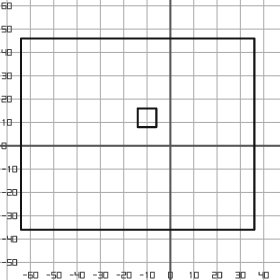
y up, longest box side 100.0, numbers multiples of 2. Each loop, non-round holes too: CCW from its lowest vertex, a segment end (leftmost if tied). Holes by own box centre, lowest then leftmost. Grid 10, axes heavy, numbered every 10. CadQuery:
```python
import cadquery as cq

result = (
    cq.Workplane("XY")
    .moveTo(-64.0, -36.0)
    .lineTo(36.0, -36.0)
    .lineTo(36.0, 46.0)
    .lineTo(-64.0, 46.0)
    .close()
    .moveTo(-14.0, 8.0)
    .lineTo(-6.0, 8.0)
    .lineTo(-6.0, 16.0)
    .lineTo(-14.0, 16.0)
    .close()
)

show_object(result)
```